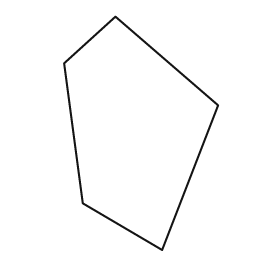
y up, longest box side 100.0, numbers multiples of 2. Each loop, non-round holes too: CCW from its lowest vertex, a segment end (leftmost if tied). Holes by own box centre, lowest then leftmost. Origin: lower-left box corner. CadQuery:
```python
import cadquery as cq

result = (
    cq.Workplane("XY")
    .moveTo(42.0, 0.0)
    .lineTo(66.0, 62.0)
    .lineTo(22.0, 100.0)
    .lineTo(0.0, 80.0)
    .lineTo(8.0, 20.0)
    .close()
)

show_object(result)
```